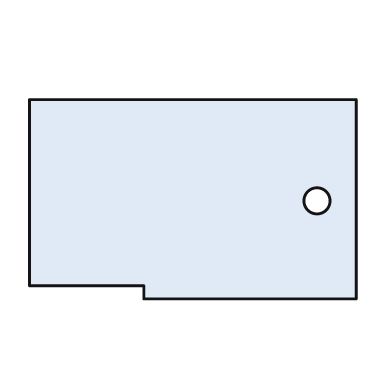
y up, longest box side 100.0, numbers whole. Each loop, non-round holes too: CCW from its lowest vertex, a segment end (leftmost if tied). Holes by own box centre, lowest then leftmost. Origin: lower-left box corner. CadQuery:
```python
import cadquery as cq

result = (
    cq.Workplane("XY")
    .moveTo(35.0, 0.0)
    .lineTo(100.0, 0.0)
    .lineTo(100.0, 61.0)
    .lineTo(0.0, 61.0)
    .lineTo(0.0, 4.0)
    .lineTo(35.0, 4.0)
    .close()
    .moveTo(88.0, 30.0)
    .circle(4.0)
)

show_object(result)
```